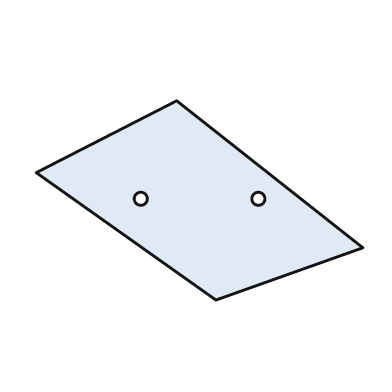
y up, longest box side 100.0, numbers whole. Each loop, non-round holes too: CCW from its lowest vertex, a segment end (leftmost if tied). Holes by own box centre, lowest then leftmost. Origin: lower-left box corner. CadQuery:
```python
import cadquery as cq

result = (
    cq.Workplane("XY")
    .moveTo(55.0, 0.0)
    .lineTo(100.0, 16.0)
    .lineTo(43.0, 61.0)
    .lineTo(0.0, 39.0)
    .close()
    .moveTo(32.0, 31.0)
    .circle(2.0)
    .moveTo(68.0, 31.0)
    .circle(2.0)
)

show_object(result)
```